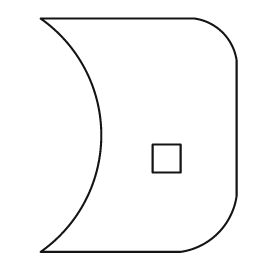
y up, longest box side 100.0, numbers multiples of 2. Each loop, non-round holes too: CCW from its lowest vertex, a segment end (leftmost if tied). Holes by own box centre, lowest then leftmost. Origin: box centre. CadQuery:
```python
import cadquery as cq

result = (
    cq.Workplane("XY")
    .moveTo(-42.0, -50.0)
    .lineTo(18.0, -50.0)
    .threePointArc((34.0, -42.0), (42.0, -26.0))
    .lineTo(42.0, 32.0)
    .threePointArc((36.0, 44.0), (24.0, 50.0))
    .lineTo(-42.0, 50.0)
    .threePointArc((-16.0, 0.0), (-42.0, -50.0))
    .close()
    .moveTo(6.0, -16.0)
    .lineTo(18.0, -16.0)
    .lineTo(18.0, -4.0)
    .lineTo(6.0, -4.0)
    .close()
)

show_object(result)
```